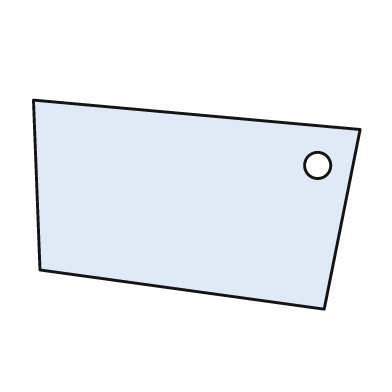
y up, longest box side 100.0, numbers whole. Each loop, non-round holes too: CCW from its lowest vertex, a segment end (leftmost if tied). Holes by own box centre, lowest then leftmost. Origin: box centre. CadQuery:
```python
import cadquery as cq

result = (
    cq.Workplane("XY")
    .moveTo(39.0, -32.0)
    .lineTo(50.0, 23.0)
    .lineTo(-50.0, 32.0)
    .lineTo(-48.0, -20.0)
    .close()
    .moveTo(37.0, 12.0)
    .circle(4.0)
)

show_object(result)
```